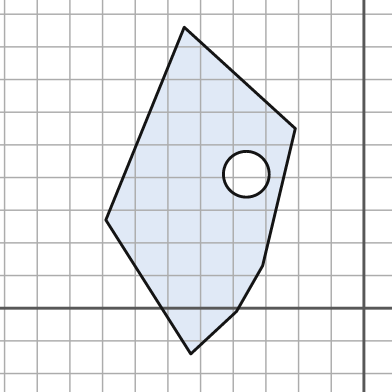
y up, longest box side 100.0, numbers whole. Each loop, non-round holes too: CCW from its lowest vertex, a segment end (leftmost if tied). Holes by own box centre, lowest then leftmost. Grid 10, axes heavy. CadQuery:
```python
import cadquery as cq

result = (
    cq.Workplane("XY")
    .moveTo(-53.0, -14.0)
    .lineTo(-39.0, -1.0)
    .lineTo(-31.0, 13.0)
    .lineTo(-21.0, 55.0)
    .lineTo(-55.0, 86.0)
    .lineTo(-79.0, 27.0)
    .close()
    .moveTo(-36.0, 41.0)
    .circle(7.0)
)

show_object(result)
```